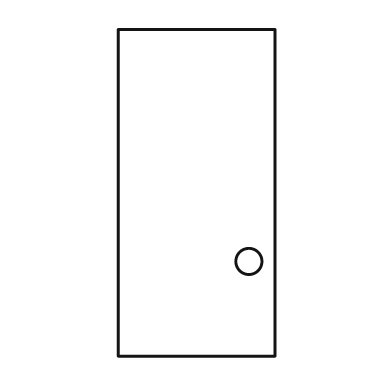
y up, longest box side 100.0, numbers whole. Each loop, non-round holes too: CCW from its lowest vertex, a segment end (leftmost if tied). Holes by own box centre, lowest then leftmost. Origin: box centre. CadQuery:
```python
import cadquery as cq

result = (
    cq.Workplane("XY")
    .moveTo(-24.0, -50.0)
    .lineTo(24.0, -50.0)
    .lineTo(24.0, 50.0)
    .lineTo(-24.0, 50.0)
    .close()
    .moveTo(16.0, -21.0)
    .circle(4.0)
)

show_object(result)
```